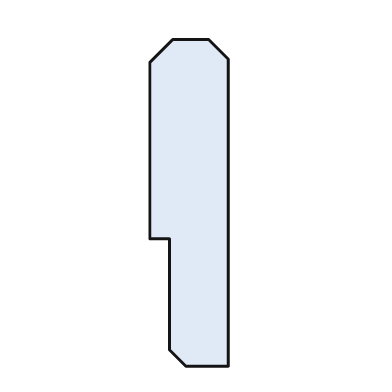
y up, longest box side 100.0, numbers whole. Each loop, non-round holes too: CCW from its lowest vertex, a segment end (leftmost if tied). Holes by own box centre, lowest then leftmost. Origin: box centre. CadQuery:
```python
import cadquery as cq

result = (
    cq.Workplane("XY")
    .moveTo(-1.0, -50.0)
    .lineTo(12.0, -50.0)
    .lineTo(12.0, 44.0)
    .lineTo(6.0, 50.0)
    .lineTo(-5.0, 50.0)
    .lineTo(-12.0, 43.0)
    .lineTo(-12.0, -11.0)
    .lineTo(-6.0, -11.0)
    .lineTo(-6.0, -45.0)
    .close()
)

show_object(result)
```